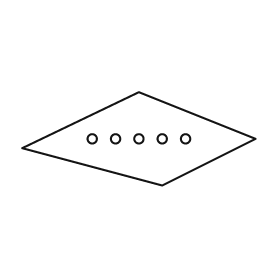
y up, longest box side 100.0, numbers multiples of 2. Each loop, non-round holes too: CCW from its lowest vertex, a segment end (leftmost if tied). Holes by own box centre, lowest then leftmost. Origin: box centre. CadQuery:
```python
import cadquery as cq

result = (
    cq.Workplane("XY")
    .moveTo(10.0, -20.0)
    .lineTo(50.0, 0.0)
    .lineTo(0.0, 20.0)
    .lineTo(-50.0, -4.0)
    .close()
    .moveTo(-20.0, 0.0)
    .circle(2.0)
    .moveTo(-10.0, 0.0)
    .circle(2.0)
    .moveTo(0.0, 0.0)
    .circle(2.0)
    .moveTo(10.0, 0.0)
    .circle(2.0)
    .moveTo(20.0, 0.0)
    .circle(2.0)
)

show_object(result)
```